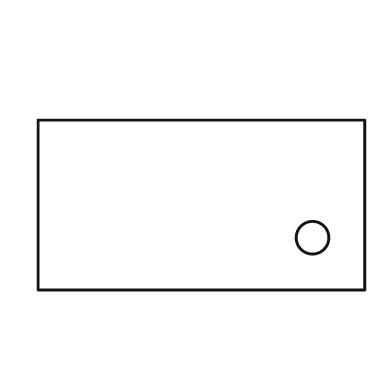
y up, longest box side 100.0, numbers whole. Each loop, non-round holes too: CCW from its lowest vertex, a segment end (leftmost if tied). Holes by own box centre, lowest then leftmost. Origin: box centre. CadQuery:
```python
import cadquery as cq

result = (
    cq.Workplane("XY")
    .moveTo(-50.0, -26.0)
    .lineTo(50.0, -26.0)
    .lineTo(50.0, 26.0)
    .lineTo(-50.0, 26.0)
    .close()
    .moveTo(34.0, -10.0)
    .circle(5.0)
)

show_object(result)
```